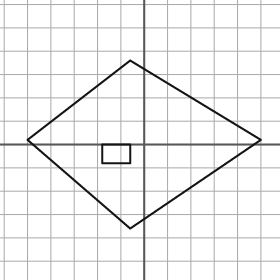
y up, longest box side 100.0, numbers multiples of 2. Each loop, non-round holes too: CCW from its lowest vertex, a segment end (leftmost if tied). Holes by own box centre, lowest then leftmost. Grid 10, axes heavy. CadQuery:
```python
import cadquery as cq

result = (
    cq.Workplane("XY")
    .moveTo(-6.0, -36.0)
    .lineTo(50.0, 2.0)
    .lineTo(-6.0, 36.0)
    .lineTo(-50.0, 2.0)
    .close()
    .moveTo(-18.0, -8.0)
    .lineTo(-6.0, -8.0)
    .lineTo(-6.0, 0.0)
    .lineTo(-18.0, 0.0)
    .close()
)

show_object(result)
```